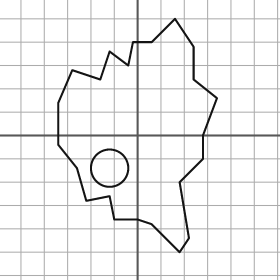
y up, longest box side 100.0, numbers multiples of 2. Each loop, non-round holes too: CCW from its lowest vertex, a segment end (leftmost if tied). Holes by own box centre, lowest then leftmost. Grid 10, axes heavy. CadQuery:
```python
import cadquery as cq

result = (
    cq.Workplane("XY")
    .moveTo(18.0, -50.0)
    .lineTo(22.0, -44.0)
    .lineTo(18.0, -20.0)
    .lineTo(28.0, -10.0)
    .lineTo(28.0, 0.0)
    .lineTo(34.0, 16.0)
    .lineTo(24.0, 24.0)
    .lineTo(24.0, 38.0)
    .lineTo(16.0, 50.0)
    .lineTo(6.0, 40.0)
    .lineTo(-2.0, 40.0)
    .lineTo(-4.0, 30.0)
    .lineTo(-12.0, 36.0)
    .lineTo(-16.0, 24.0)
    .lineTo(-28.0, 28.0)
    .lineTo(-34.0, 14.0)
    .lineTo(-34.0, -4.0)
    .lineTo(-26.0, -14.0)
    .lineTo(-22.0, -28.0)
    .lineTo(-12.0, -26.0)
    .lineTo(-10.0, -36.0)
    .lineTo(0.0, -36.0)
    .lineTo(6.0, -38.0)
    .close()
    .moveTo(-12.0, -14.0)
    .circle(8.0)
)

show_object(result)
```